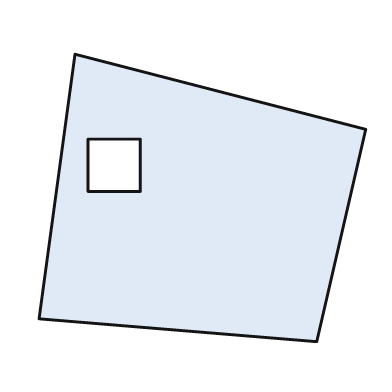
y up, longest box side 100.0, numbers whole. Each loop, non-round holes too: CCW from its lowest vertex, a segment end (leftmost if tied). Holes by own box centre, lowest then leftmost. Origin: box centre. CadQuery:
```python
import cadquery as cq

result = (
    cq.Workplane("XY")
    .moveTo(35.0, -44.0)
    .lineTo(50.0, 21.0)
    .lineTo(-39.0, 44.0)
    .lineTo(-50.0, -37.0)
    .close()
    .moveTo(-35.0, 2.0)
    .lineTo(-19.0, 2.0)
    .lineTo(-19.0, 18.0)
    .lineTo(-35.0, 18.0)
    .close()
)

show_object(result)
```